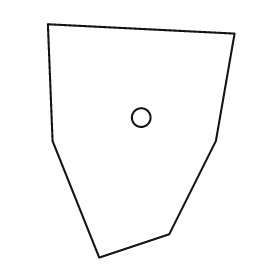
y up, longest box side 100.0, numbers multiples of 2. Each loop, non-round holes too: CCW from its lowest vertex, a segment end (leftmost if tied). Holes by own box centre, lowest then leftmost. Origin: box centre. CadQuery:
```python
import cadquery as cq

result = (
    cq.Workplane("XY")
    .moveTo(-18.0, -50.0)
    .lineTo(12.0, -40.0)
    .lineTo(32.0, 0.0)
    .lineTo(40.0, 46.0)
    .lineTo(-40.0, 50.0)
    .lineTo(-38.0, 0.0)
    .close()
    .moveTo(0.0, 10.0)
    .circle(4.0)
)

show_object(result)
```